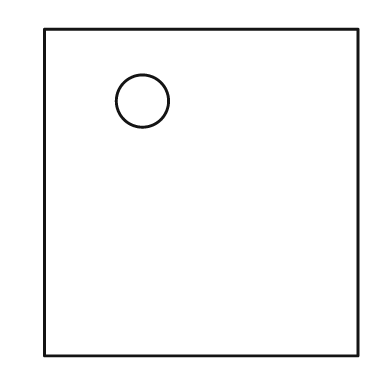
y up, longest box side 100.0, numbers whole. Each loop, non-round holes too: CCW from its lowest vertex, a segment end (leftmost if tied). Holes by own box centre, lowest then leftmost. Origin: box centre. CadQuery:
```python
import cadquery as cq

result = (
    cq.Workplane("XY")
    .moveTo(-48.0, -50.0)
    .lineTo(48.0, -50.0)
    .lineTo(48.0, 50.0)
    .lineTo(-48.0, 50.0)
    .close()
    .moveTo(-18.0, 28.0)
    .circle(8.0)
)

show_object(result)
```